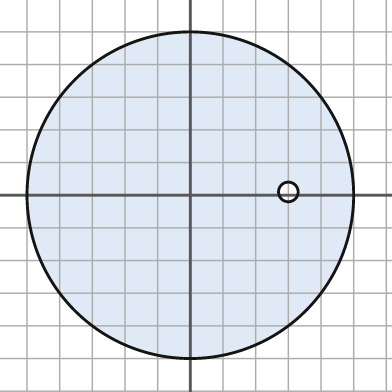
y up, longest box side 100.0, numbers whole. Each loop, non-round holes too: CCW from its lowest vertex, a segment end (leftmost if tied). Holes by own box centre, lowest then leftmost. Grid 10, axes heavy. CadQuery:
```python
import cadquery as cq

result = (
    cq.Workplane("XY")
    .moveTo(0.0, 0.0)
    .circle(50.0)
    .moveTo(30.0, 1.0)
    .circle(3.0)
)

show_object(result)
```